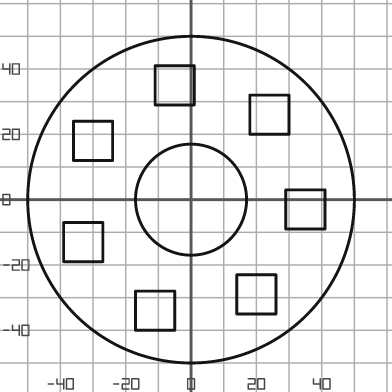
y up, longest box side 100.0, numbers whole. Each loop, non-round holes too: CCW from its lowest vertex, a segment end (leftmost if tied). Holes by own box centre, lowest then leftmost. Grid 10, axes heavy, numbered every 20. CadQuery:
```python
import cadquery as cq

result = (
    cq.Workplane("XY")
    .moveTo(0.0, 0.0)
    .circle(50.0)
    .moveTo(-17.0, -40.0)
    .lineTo(-5.0, -40.0)
    .lineTo(-5.0, -28.0)
    .lineTo(-17.0, -28.0)
    .close()
    .moveTo(14.0, -35.0)
    .lineTo(26.0, -35.0)
    .lineTo(26.0, -23.0)
    .lineTo(14.0, -23.0)
    .close()
    .moveTo(-39.0, -19.0)
    .lineTo(-27.0, -19.0)
    .lineTo(-27.0, -7.0)
    .lineTo(-39.0, -7.0)
    .close()
    .moveTo(29.0, -9.0)
    .lineTo(41.0, -9.0)
    .lineTo(41.0, 3.0)
    .lineTo(29.0, 3.0)
    .close()
    .moveTo(0.0, 0.0)
    .circle(17.0)
    .moveTo(-36.0, 12.0)
    .lineTo(-24.0, 12.0)
    .lineTo(-24.0, 24.0)
    .lineTo(-36.0, 24.0)
    .close()
    .moveTo(18.0, 20.0)
    .lineTo(30.0, 20.0)
    .lineTo(30.0, 32.0)
    .lineTo(18.0, 32.0)
    .close()
    .moveTo(-11.0, 29.0)
    .lineTo(1.0, 29.0)
    .lineTo(1.0, 41.0)
    .lineTo(-11.0, 41.0)
    .close()
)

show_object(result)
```